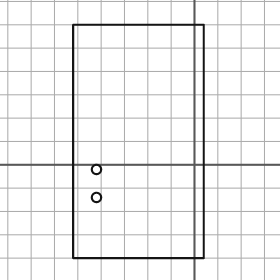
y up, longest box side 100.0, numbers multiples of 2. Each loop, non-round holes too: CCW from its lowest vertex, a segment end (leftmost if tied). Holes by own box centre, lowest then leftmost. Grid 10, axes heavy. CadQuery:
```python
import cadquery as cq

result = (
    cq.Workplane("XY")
    .moveTo(-52.0, -40.0)
    .lineTo(4.0, -40.0)
    .lineTo(4.0, 60.0)
    .lineTo(-52.0, 60.0)
    .close()
    .moveTo(-42.0, -14.0)
    .circle(2.0)
    .moveTo(-42.0, -2.0)
    .circle(2.0)
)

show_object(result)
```